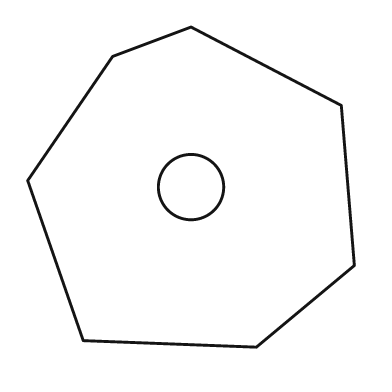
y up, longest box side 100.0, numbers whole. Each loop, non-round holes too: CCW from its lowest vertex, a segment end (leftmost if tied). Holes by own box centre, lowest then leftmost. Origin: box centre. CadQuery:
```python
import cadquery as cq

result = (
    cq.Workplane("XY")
    .moveTo(20.0, -49.0)
    .lineTo(50.0, -24.0)
    .lineTo(46.0, 25.0)
    .lineTo(0.0, 49.0)
    .lineTo(-24.0, 40.0)
    .lineTo(-50.0, 2.0)
    .lineTo(-33.0, -47.0)
    .close()
    .moveTo(0.0, 0.0)
    .circle(10.0)
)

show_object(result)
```